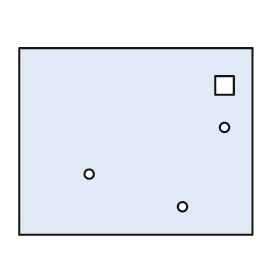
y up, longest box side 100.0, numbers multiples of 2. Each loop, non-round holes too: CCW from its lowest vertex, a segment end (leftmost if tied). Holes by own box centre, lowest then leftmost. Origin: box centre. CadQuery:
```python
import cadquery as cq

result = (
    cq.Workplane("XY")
    .moveTo(-50.0, -40.0)
    .lineTo(50.0, -40.0)
    .lineTo(50.0, 40.0)
    .lineTo(-50.0, 40.0)
    .close()
    .moveTo(20.0, -28.0)
    .circle(2.0)
    .moveTo(-20.0, -14.0)
    .circle(2.0)
    .moveTo(38.0, 6.0)
    .circle(2.0)
    .moveTo(34.0, 20.0)
    .lineTo(42.0, 20.0)
    .lineTo(42.0, 28.0)
    .lineTo(34.0, 28.0)
    .close()
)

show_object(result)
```